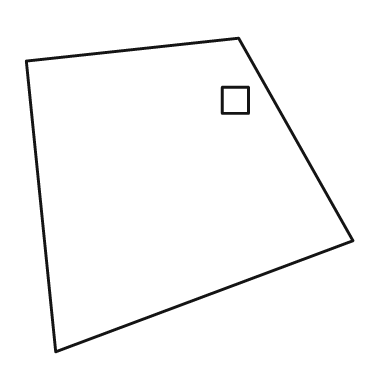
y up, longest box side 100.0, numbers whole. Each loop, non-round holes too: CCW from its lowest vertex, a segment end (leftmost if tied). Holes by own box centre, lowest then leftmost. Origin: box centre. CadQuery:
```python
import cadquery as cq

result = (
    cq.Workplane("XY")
    .moveTo(-41.0, -48.0)
    .lineTo(50.0, -14.0)
    .lineTo(15.0, 48.0)
    .lineTo(-50.0, 41.0)
    .close()
    .moveTo(10.0, 25.0)
    .lineTo(18.0, 25.0)
    .lineTo(18.0, 33.0)
    .lineTo(10.0, 33.0)
    .close()
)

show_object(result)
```